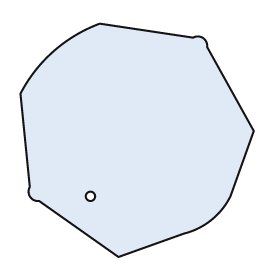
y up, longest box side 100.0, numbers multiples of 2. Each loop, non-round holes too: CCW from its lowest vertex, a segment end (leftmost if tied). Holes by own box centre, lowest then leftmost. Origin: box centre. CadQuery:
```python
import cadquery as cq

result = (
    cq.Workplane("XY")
    .moveTo(-8.0, -50.0)
    .lineTo(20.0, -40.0)
    .threePointArc((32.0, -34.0), (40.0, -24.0))
    .lineTo(50.0, 4.0)
    .lineTo(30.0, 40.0)
    .threePointArc((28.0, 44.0), (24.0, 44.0))
    .lineTo(-16.0, 50.0)
    .threePointArc((-36.0, 38.0), (-50.0, 20.0))
    .lineTo(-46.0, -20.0)
    .threePointArc((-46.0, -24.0), (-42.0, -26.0))
    .close()
    .moveTo(-20.0, -24.0)
    .circle(2.0)
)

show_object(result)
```